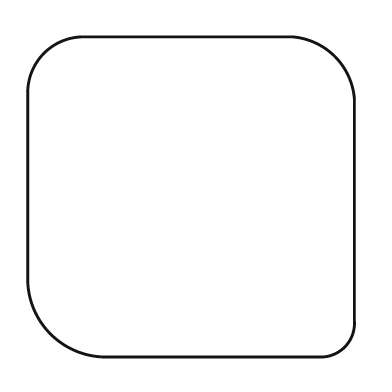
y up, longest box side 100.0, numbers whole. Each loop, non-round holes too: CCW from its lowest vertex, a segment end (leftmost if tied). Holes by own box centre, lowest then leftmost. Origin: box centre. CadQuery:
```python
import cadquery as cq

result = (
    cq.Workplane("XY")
    .moveTo(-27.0, -49.0)
    .lineTo(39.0, -49.0)
    .threePointArc((47.0, -46.0), (50.0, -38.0))
    .lineTo(50.0, 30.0)
    .threePointArc((44.0, 43.0), (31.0, 49.0))
    .lineTo(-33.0, 49.0)
    .threePointArc((-45.0, 44.0), (-50.0, 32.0))
    .lineTo(-50.0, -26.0)
    .threePointArc((-43.0, -42.0), (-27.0, -49.0))
    .close()
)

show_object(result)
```